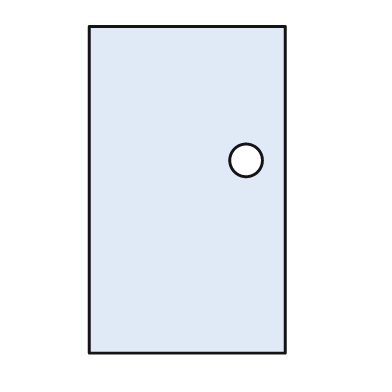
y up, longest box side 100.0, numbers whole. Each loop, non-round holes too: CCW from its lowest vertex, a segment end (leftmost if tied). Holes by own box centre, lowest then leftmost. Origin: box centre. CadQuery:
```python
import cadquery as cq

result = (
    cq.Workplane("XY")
    .moveTo(-30.0, -50.0)
    .lineTo(30.0, -50.0)
    .lineTo(30.0, 50.0)
    .lineTo(-30.0, 50.0)
    .close()
    .moveTo(18.0, 9.0)
    .circle(5.0)
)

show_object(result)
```